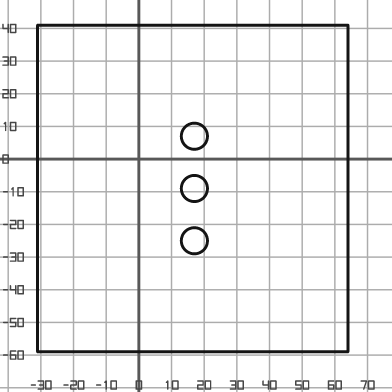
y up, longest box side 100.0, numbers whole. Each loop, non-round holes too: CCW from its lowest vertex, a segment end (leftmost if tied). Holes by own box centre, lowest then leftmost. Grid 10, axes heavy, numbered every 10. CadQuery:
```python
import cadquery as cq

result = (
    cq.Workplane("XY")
    .moveTo(-31.0, -59.0)
    .lineTo(64.0, -59.0)
    .lineTo(64.0, 41.0)
    .lineTo(-31.0, 41.0)
    .close()
    .moveTo(17.0, -25.0)
    .circle(4.0)
    .moveTo(17.0, -9.0)
    .circle(4.0)
    .moveTo(17.0, 7.0)
    .circle(4.0)
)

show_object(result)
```